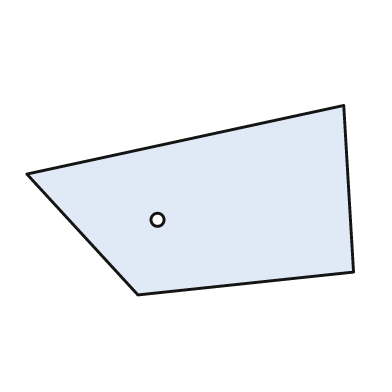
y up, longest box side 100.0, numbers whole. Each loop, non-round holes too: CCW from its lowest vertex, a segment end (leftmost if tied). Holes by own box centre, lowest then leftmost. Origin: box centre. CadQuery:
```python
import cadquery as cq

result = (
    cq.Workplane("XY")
    .moveTo(-16.0, -29.0)
    .lineTo(50.0, -22.0)
    .lineTo(47.0, 29.0)
    .lineTo(-50.0, 8.0)
    .close()
    .moveTo(-10.0, -6.0)
    .circle(2.0)
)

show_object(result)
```